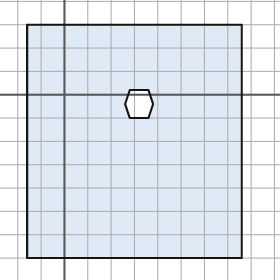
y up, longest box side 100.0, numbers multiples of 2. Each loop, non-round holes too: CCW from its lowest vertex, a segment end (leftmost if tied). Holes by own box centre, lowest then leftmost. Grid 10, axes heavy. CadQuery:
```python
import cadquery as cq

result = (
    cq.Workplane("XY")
    .moveTo(-16.0, -70.0)
    .lineTo(76.0, -70.0)
    .lineTo(76.0, 30.0)
    .lineTo(-16.0, 30.0)
    .close()
    .moveTo(28.0, -10.0)
    .lineTo(36.0, -10.0)
    .lineTo(38.0, -4.0)
    .lineTo(36.0, 2.0)
    .lineTo(28.0, 2.0)
    .lineTo(26.0, -4.0)
    .close()
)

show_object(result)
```